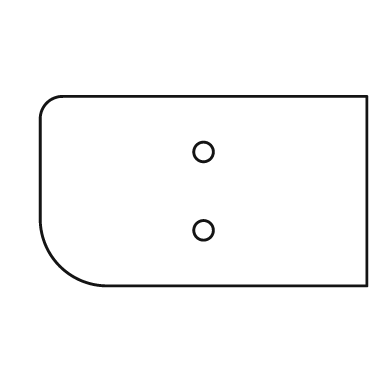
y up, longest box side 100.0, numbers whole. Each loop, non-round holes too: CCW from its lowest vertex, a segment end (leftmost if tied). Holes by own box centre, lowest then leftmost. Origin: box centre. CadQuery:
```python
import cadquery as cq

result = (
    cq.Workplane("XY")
    .moveTo(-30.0, -29.0)
    .lineTo(50.0, -29.0)
    .lineTo(50.0, 29.0)
    .lineTo(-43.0, 29.0)
    .threePointArc((-48.0, 27.0), (-50.0, 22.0))
    .lineTo(-50.0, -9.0)
    .threePointArc((-44.0, -23.0), (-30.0, -29.0))
    .close()
    .moveTo(0.0, -12.0)
    .circle(3.0)
    .moveTo(0.0, 12.0)
    .circle(3.0)
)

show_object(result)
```